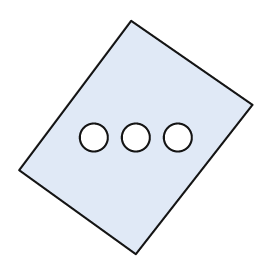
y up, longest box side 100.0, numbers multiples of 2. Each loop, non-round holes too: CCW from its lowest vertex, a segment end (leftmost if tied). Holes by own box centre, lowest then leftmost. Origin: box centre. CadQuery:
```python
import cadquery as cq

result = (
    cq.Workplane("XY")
    .moveTo(0.0, -50.0)
    .lineTo(50.0, 14.0)
    .lineTo(-2.0, 50.0)
    .lineTo(-50.0, -14.0)
    .close()
    .moveTo(-18.0, 0.0)
    .circle(6.0)
    .moveTo(0.0, 0.0)
    .circle(6.0)
    .moveTo(18.0, 0.0)
    .circle(6.0)
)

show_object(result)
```